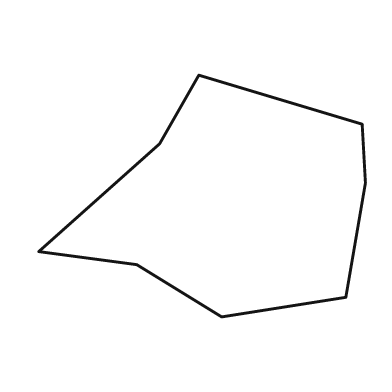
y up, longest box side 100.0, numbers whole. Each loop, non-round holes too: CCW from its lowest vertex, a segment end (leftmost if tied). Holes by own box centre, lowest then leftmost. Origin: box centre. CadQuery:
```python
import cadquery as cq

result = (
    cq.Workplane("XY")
    .moveTo(6.0, -37.0)
    .lineTo(44.0, -31.0)
    .lineTo(50.0, 4.0)
    .lineTo(49.0, 22.0)
    .lineTo(-1.0, 37.0)
    .lineTo(-13.0, 16.0)
    .lineTo(-50.0, -17.0)
    .lineTo(-20.0, -21.0)
    .close()
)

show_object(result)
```